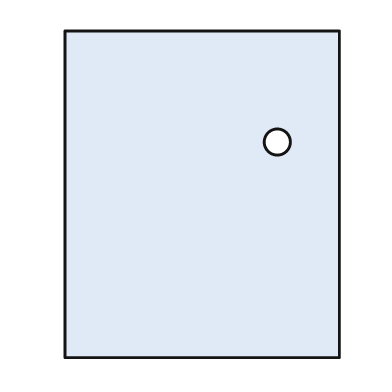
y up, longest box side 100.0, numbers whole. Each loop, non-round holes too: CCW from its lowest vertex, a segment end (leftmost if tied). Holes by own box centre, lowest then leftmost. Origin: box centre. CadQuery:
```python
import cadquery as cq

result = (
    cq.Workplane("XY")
    .moveTo(-42.0, -50.0)
    .lineTo(42.0, -50.0)
    .lineTo(42.0, 50.0)
    .lineTo(-42.0, 50.0)
    .close()
    .moveTo(23.0, 16.0)
    .circle(4.0)
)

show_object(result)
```